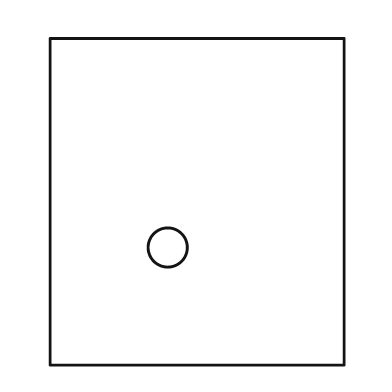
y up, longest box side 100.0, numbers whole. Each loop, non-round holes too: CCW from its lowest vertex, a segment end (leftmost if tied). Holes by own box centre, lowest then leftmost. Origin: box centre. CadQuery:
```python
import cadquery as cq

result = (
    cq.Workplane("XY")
    .moveTo(-45.0, -50.0)
    .lineTo(45.0, -50.0)
    .lineTo(45.0, 50.0)
    .lineTo(-45.0, 50.0)
    .close()
    .moveTo(-9.0, -14.0)
    .circle(6.0)
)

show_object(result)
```